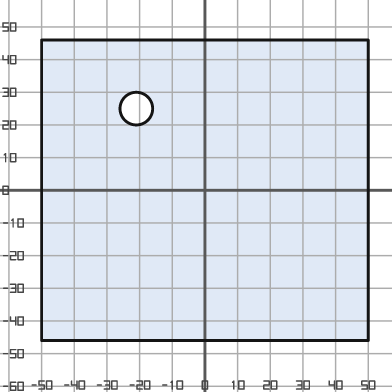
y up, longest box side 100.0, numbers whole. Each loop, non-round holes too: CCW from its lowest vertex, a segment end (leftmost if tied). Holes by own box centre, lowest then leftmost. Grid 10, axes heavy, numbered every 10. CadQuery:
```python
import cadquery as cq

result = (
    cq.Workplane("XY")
    .moveTo(-50.0, -46.0)
    .lineTo(50.0, -46.0)
    .lineTo(50.0, 46.0)
    .lineTo(-50.0, 46.0)
    .close()
    .moveTo(-21.0, 25.0)
    .circle(5.0)
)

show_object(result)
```